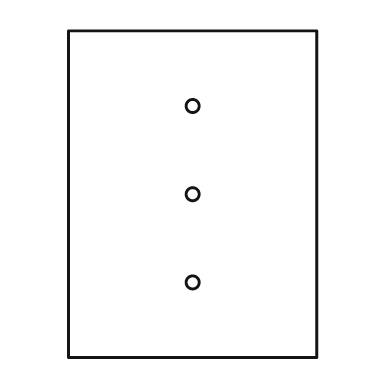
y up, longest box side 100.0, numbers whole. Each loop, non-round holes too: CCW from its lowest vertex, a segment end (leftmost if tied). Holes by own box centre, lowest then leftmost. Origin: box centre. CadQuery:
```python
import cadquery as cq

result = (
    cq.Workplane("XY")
    .moveTo(-38.0, -50.0)
    .lineTo(38.0, -50.0)
    .lineTo(38.0, 50.0)
    .lineTo(-38.0, 50.0)
    .close()
    .moveTo(0.0, -27.0)
    .circle(2.0)
    .moveTo(0.0, 0.0)
    .circle(2.0)
    .moveTo(0.0, 27.0)
    .circle(2.0)
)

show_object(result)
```